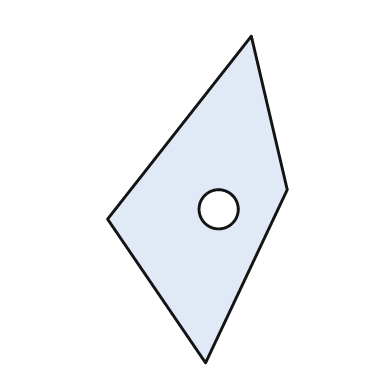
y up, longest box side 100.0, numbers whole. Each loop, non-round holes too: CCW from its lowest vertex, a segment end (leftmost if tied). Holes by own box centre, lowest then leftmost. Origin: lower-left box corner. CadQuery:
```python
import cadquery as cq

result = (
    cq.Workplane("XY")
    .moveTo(30.0, 0.0)
    .lineTo(55.0, 53.0)
    .lineTo(44.0, 100.0)
    .lineTo(0.0, 44.0)
    .close()
    .moveTo(34.0, 47.0)
    .circle(6.0)
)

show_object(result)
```